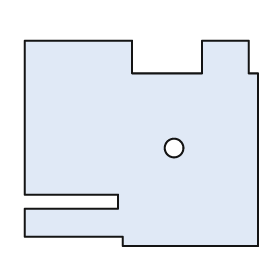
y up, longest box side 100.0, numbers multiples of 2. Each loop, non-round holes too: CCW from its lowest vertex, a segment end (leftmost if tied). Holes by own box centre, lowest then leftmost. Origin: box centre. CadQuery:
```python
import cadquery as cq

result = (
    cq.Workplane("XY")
    .moveTo(-8.0, -44.0)
    .lineTo(50.0, -44.0)
    .lineTo(50.0, 30.0)
    .lineTo(46.0, 30.0)
    .lineTo(46.0, 44.0)
    .lineTo(26.0, 44.0)
    .lineTo(26.0, 30.0)
    .lineTo(-4.0, 30.0)
    .lineTo(-4.0, 44.0)
    .lineTo(-50.0, 44.0)
    .lineTo(-50.0, -22.0)
    .lineTo(-10.0, -22.0)
    .lineTo(-10.0, -28.0)
    .lineTo(-50.0, -28.0)
    .lineTo(-50.0, -40.0)
    .lineTo(-8.0, -40.0)
    .close()
    .moveTo(14.0, -2.0)
    .circle(4.0)
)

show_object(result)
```